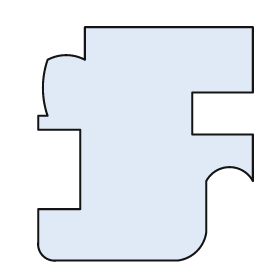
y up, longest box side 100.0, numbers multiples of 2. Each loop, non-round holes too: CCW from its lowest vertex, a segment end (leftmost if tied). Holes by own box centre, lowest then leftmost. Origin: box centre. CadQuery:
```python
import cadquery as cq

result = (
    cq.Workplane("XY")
    .moveTo(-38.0, -50.0)
    .lineTo(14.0, -50.0)
    .threePointArc((22.0, -46.0), (26.0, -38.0))
    .lineTo(26.0, -16.0)
    .threePointArc((36.0, -10.0), (46.0, -16.0))
    .lineTo(46.0, 4.0)
    .lineTo(20.0, 4.0)
    .lineTo(20.0, 22.0)
    .lineTo(46.0, 22.0)
    .lineTo(46.0, 50.0)
    .lineTo(-26.0, 50.0)
    .lineTo(-26.0, 36.0)
    .threePointArc((-34.0, 38.0), (-42.0, 36.0))
    .threePointArc((-44.0, 24.0), (-42.0, 12.0))
    .lineTo(-46.0, 12.0)
    .lineTo(-46.0, 6.0)
    .lineTo(-28.0, 6.0)
    .lineTo(-28.0, -28.0)
    .lineTo(-46.0, -28.0)
    .lineTo(-46.0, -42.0)
    .threePointArc((-44.0, -48.0), (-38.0, -50.0))
    .close()
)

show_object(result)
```